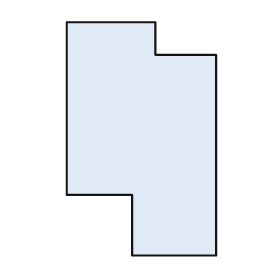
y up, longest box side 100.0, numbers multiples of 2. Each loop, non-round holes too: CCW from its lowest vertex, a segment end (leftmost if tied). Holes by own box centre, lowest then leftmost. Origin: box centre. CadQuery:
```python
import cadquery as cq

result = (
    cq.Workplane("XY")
    .moveTo(-4.0, -50.0)
    .lineTo(32.0, -50.0)
    .lineTo(32.0, 36.0)
    .lineTo(6.0, 36.0)
    .lineTo(6.0, 50.0)
    .lineTo(-32.0, 50.0)
    .lineTo(-32.0, -24.0)
    .lineTo(-4.0, -24.0)
    .close()
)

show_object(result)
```